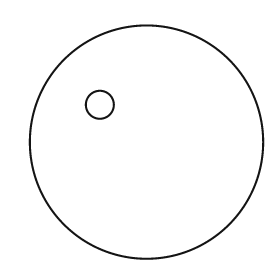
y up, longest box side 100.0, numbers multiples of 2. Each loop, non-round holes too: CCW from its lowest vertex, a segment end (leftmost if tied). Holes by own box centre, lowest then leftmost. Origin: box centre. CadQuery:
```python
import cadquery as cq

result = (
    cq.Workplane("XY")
    .moveTo(0.0, 0.0)
    .circle(50.0)
    .moveTo(-20.0, 16.0)
    .circle(6.0)
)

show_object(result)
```